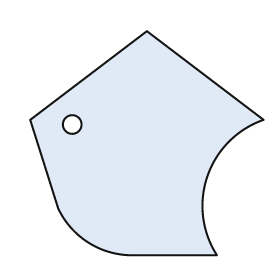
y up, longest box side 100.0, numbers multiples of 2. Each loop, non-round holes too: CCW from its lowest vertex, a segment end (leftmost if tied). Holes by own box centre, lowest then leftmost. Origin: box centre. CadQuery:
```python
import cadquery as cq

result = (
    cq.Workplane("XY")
    .moveTo(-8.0, -48.0)
    .lineTo(30.0, -48.0)
    .threePointArc((26.0, -14.0), (50.0, 10.0))
    .lineTo(0.0, 48.0)
    .lineTo(-50.0, 10.0)
    .lineTo(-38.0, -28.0)
    .threePointArc((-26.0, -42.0), (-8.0, -48.0))
    .close()
    .moveTo(-32.0, 8.0)
    .circle(4.0)
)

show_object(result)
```